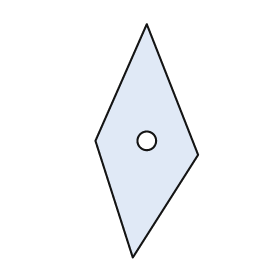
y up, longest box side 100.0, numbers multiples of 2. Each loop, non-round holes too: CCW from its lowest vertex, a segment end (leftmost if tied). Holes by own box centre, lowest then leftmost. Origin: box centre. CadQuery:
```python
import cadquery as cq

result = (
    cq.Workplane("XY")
    .moveTo(-6.0, -50.0)
    .lineTo(22.0, -6.0)
    .lineTo(0.0, 50.0)
    .lineTo(-22.0, 0.0)
    .close()
    .moveTo(0.0, 0.0)
    .circle(4.0)
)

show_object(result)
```